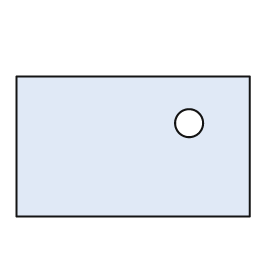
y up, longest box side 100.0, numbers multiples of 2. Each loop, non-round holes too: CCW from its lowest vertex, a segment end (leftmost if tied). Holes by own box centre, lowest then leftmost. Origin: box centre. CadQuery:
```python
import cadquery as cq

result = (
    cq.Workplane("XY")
    .moveTo(-50.0, -30.0)
    .lineTo(50.0, -30.0)
    .lineTo(50.0, 30.0)
    .lineTo(-50.0, 30.0)
    .close()
    .moveTo(24.0, 10.0)
    .circle(6.0)
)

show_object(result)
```